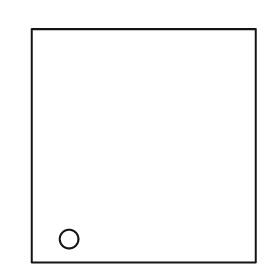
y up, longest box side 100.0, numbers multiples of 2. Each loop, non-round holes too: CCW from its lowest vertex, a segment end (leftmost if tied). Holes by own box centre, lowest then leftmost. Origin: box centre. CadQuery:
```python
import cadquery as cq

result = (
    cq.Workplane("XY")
    .moveTo(-48.0, -50.0)
    .lineTo(48.0, -50.0)
    .lineTo(48.0, 50.0)
    .lineTo(-48.0, 50.0)
    .close()
    .moveTo(-32.0, -40.0)
    .circle(4.0)
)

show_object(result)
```